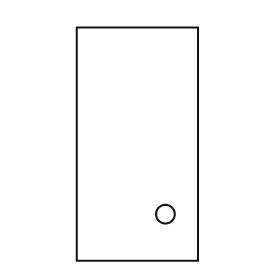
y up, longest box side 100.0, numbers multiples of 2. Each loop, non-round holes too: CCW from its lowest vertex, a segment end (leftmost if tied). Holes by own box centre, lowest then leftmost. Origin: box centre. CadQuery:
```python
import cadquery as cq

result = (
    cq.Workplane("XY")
    .moveTo(-26.0, -50.0)
    .lineTo(26.0, -50.0)
    .lineTo(26.0, 50.0)
    .lineTo(-26.0, 50.0)
    .close()
    .moveTo(12.0, -30.0)
    .circle(4.0)
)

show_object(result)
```